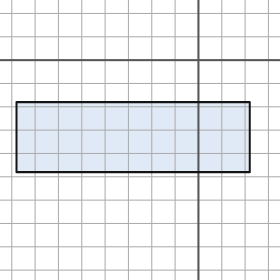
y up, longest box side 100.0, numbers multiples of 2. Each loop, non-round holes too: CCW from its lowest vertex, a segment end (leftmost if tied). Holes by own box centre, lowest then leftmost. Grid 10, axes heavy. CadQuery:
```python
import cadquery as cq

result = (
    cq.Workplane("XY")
    .moveTo(-78.0, -48.0)
    .lineTo(22.0, -48.0)
    .lineTo(22.0, -18.0)
    .lineTo(-78.0, -18.0)
    .close()
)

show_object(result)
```